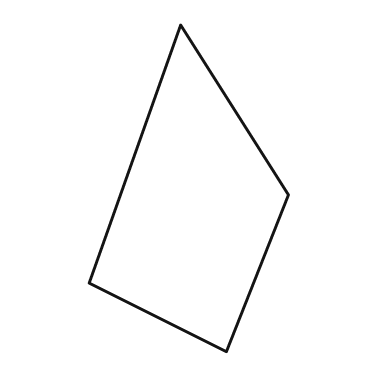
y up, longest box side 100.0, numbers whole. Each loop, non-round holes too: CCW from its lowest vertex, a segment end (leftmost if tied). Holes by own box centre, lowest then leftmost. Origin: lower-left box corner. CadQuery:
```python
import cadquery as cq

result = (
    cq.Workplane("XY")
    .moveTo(42.0, 0.0)
    .lineTo(61.0, 48.0)
    .lineTo(28.0, 100.0)
    .lineTo(0.0, 21.0)
    .close()
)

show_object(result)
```